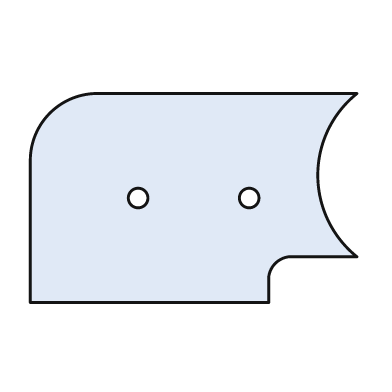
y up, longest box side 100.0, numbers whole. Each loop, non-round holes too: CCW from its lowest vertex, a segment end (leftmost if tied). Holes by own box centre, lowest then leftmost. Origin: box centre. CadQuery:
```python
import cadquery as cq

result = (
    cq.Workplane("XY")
    .moveTo(-50.0, -32.0)
    .lineTo(23.0, -32.0)
    .lineTo(23.0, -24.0)
    .threePointArc((25.0, -20.0), (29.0, -18.0))
    .lineTo(50.0, -18.0)
    .threePointArc((38.0, 7.0), (50.0, 32.0))
    .lineTo(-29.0, 32.0)
    .threePointArc((-44.0, 26.0), (-50.0, 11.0))
    .close()
    .moveTo(-17.0, 0.0)
    .circle(3.0)
    .moveTo(17.0, 0.0)
    .circle(3.0)
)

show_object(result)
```